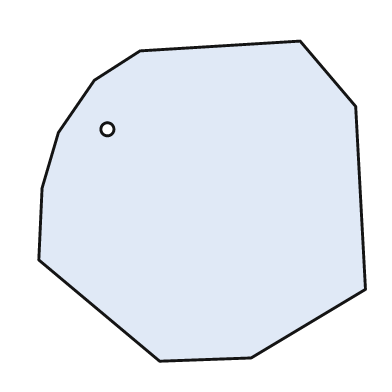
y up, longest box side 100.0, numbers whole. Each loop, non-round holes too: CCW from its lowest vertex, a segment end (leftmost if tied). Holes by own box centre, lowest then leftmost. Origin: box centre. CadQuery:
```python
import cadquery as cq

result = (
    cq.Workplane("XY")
    .moveTo(-13.0, -49.0)
    .lineTo(15.0, -48.0)
    .lineTo(50.0, -27.0)
    .lineTo(47.0, 29.0)
    .lineTo(30.0, 49.0)
    .lineTo(-19.0, 46.0)
    .lineTo(-33.0, 37.0)
    .lineTo(-44.0, 21.0)
    .lineTo(-49.0, 4.0)
    .lineTo(-50.0, -18.0)
    .close()
    .moveTo(-29.0, 22.0)
    .circle(2.0)
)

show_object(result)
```